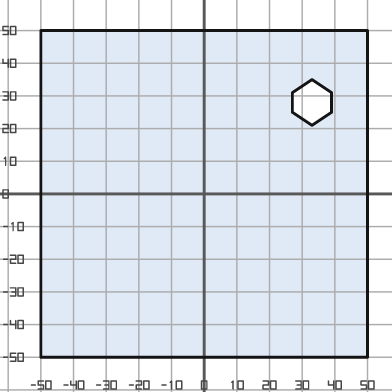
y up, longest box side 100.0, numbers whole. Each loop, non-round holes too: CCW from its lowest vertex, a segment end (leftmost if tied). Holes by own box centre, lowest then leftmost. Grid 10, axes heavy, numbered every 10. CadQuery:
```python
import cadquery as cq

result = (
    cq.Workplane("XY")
    .moveTo(-50.0, -50.0)
    .lineTo(50.0, -50.0)
    .lineTo(50.0, 50.0)
    .lineTo(-50.0, 50.0)
    .close()
    .moveTo(33.0, 21.0)
    .lineTo(39.0, 25.0)
    .lineTo(39.0, 31.0)
    .lineTo(33.0, 35.0)
    .lineTo(27.0, 31.0)
    .lineTo(27.0, 25.0)
    .close()
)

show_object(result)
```